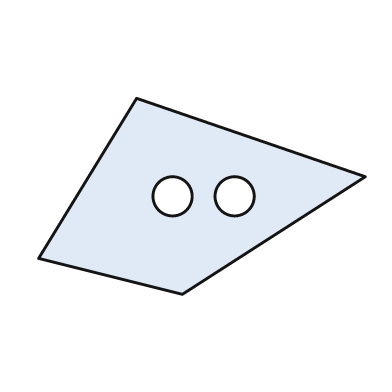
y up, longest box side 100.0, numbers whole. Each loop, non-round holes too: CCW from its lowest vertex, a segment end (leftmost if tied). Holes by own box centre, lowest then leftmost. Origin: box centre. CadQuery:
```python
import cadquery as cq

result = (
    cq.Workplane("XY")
    .moveTo(-6.0, -30.0)
    .lineTo(50.0, 6.0)
    .lineTo(-20.0, 30.0)
    .lineTo(-50.0, -19.0)
    .close()
    .moveTo(-9.0, 0.0)
    .circle(6.0)
    .moveTo(10.0, 0.0)
    .circle(6.0)
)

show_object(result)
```